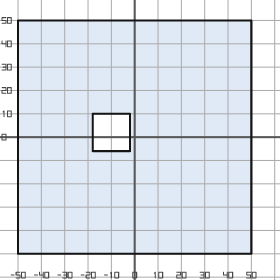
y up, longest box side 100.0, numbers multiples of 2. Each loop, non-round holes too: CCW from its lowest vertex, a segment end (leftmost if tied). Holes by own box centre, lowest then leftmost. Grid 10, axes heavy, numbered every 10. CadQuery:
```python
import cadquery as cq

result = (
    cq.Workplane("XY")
    .moveTo(-50.0, -50.0)
    .lineTo(50.0, -50.0)
    .lineTo(50.0, 50.0)
    .lineTo(-50.0, 50.0)
    .close()
    .moveTo(-18.0, -6.0)
    .lineTo(-2.0, -6.0)
    .lineTo(-2.0, 10.0)
    .lineTo(-18.0, 10.0)
    .close()
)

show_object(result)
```